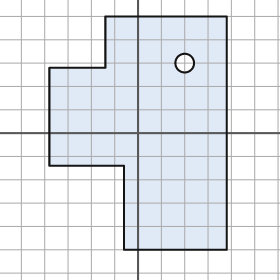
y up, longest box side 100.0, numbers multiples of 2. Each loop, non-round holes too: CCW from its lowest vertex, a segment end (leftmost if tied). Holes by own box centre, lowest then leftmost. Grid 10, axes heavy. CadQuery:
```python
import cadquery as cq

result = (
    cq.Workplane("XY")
    .moveTo(-6.0, -50.0)
    .lineTo(38.0, -50.0)
    .lineTo(38.0, 50.0)
    .lineTo(-14.0, 50.0)
    .lineTo(-14.0, 28.0)
    .lineTo(-38.0, 28.0)
    .lineTo(-38.0, -14.0)
    .lineTo(-6.0, -14.0)
    .close()
    .moveTo(20.0, 30.0)
    .circle(4.0)
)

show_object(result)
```